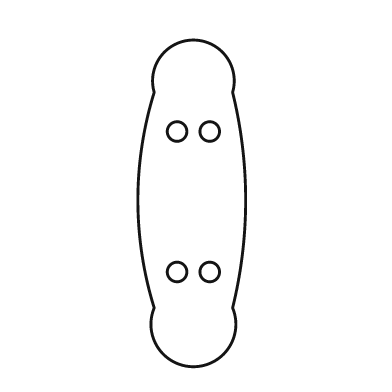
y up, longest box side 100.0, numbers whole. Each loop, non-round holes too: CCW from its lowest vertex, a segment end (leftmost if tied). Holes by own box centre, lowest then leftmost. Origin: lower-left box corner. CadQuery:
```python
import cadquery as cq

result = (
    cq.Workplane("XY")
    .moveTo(5.0, 18.0)
    .threePointArc((17.0, 0.0), (29.0, 18.0))
    .threePointArc((33.0, 51.0), (29.0, 84.0))
    .threePointArc((17.0, 100.0), (5.0, 84.0))
    .threePointArc((0.0, 51.0), (5.0, 18.0))
    .close()
    .moveTo(12.0, 29.0)
    .circle(3.0)
    .moveTo(22.0, 29.0)
    .circle(3.0)
    .moveTo(12.0, 72.0)
    .circle(3.0)
    .moveTo(22.0, 72.0)
    .circle(3.0)
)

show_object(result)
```